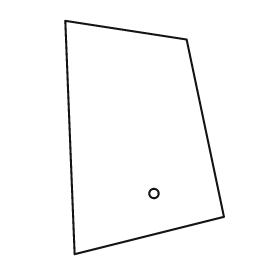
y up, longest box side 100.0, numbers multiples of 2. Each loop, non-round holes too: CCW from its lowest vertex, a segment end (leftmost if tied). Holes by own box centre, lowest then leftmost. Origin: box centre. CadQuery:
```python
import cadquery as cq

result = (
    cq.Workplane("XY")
    .moveTo(-30.0, -50.0)
    .lineTo(34.0, -34.0)
    .lineTo(18.0, 42.0)
    .lineTo(-34.0, 50.0)
    .close()
    .moveTo(4.0, -24.0)
    .circle(2.0)
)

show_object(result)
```